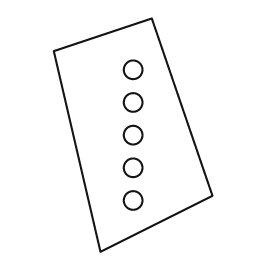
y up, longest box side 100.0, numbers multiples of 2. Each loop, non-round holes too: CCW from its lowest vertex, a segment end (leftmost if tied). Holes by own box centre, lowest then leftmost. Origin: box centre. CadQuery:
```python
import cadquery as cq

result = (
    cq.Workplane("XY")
    .moveTo(-14.0, -50.0)
    .lineTo(34.0, -26.0)
    .lineTo(8.0, 50.0)
    .lineTo(-34.0, 36.0)
    .close()
    .moveTo(0.0, -28.0)
    .circle(4.0)
    .moveTo(0.0, -14.0)
    .circle(4.0)
    .moveTo(0.0, 0.0)
    .circle(4.0)
    .moveTo(0.0, 14.0)
    .circle(4.0)
    .moveTo(0.0, 28.0)
    .circle(4.0)
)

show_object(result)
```